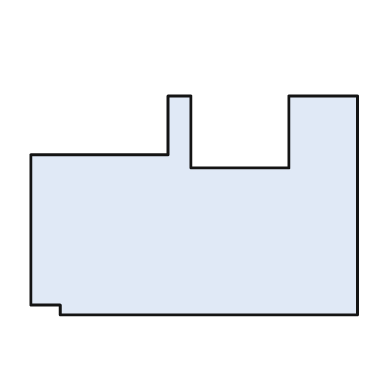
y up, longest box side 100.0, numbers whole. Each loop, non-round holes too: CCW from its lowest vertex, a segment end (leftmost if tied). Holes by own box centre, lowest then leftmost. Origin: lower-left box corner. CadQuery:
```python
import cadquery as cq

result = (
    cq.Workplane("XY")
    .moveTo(9.0, 0.0)
    .lineTo(100.0, 0.0)
    .lineTo(100.0, 67.0)
    .lineTo(79.0, 67.0)
    .lineTo(79.0, 45.0)
    .lineTo(49.0, 45.0)
    .lineTo(49.0, 67.0)
    .lineTo(42.0, 67.0)
    .lineTo(42.0, 49.0)
    .lineTo(0.0, 49.0)
    .lineTo(0.0, 3.0)
    .lineTo(9.0, 3.0)
    .close()
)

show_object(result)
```